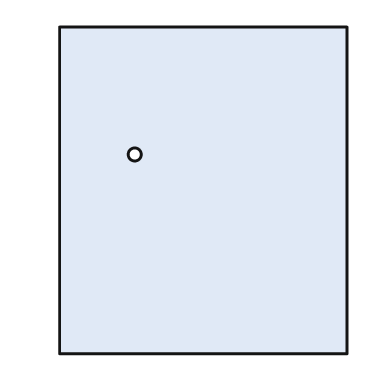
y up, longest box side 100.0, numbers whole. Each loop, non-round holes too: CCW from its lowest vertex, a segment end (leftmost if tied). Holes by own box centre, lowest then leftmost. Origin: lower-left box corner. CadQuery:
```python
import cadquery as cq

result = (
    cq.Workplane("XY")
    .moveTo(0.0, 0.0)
    .lineTo(88.0, 0.0)
    .lineTo(88.0, 100.0)
    .lineTo(0.0, 100.0)
    .close()
    .moveTo(23.0, 61.0)
    .circle(2.0)
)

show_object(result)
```